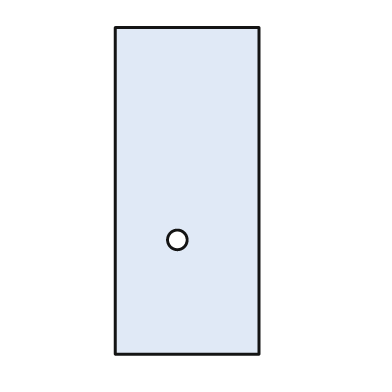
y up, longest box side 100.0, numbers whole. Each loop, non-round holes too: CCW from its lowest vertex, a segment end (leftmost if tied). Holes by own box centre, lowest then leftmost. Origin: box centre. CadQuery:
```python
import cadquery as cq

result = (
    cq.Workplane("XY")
    .moveTo(-22.0, -50.0)
    .lineTo(22.0, -50.0)
    .lineTo(22.0, 50.0)
    .lineTo(-22.0, 50.0)
    .close()
    .moveTo(-3.0, -15.0)
    .circle(3.0)
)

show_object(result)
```